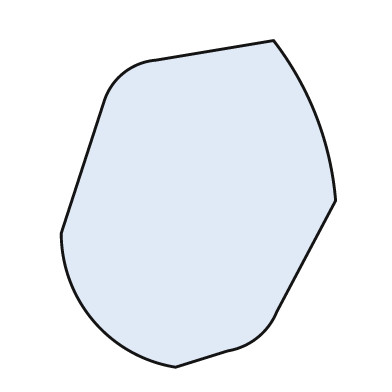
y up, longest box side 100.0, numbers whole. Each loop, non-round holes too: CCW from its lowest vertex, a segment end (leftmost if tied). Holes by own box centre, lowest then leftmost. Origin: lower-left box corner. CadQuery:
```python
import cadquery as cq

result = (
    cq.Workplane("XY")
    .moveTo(35.0, 0.0)
    .lineTo(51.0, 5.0)
    .threePointArc((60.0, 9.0), (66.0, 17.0))
    .lineTo(84.0, 51.0)
    .threePointArc((78.0, 77.0), (65.0, 100.0))
    .lineTo(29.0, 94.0)
    .threePointArc((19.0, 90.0), (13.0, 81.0))
    .lineTo(0.0, 41.0)
    .threePointArc((10.0, 14.0), (35.0, 0.0))
    .close()
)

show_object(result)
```